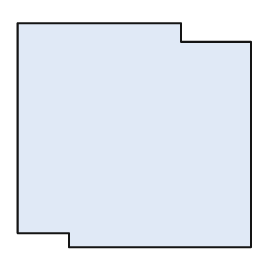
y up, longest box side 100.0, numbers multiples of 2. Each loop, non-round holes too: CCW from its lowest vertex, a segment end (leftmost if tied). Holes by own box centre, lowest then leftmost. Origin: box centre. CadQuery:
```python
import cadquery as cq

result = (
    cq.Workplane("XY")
    .moveTo(-28.0, -48.0)
    .lineTo(50.0, -48.0)
    .lineTo(50.0, 40.0)
    .lineTo(20.0, 40.0)
    .lineTo(20.0, 48.0)
    .lineTo(-50.0, 48.0)
    .lineTo(-50.0, -42.0)
    .lineTo(-28.0, -42.0)
    .close()
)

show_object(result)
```